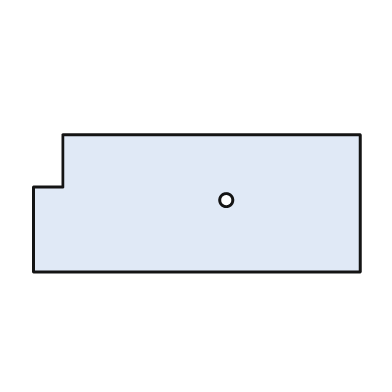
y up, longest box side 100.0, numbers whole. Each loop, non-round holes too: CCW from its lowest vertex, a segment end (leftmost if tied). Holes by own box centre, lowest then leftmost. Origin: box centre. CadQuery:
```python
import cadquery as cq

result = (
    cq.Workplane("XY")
    .moveTo(-50.0, -21.0)
    .lineTo(50.0, -21.0)
    .lineTo(50.0, 21.0)
    .lineTo(-41.0, 21.0)
    .lineTo(-41.0, 5.0)
    .lineTo(-50.0, 5.0)
    .close()
    .moveTo(9.0, 1.0)
    .circle(2.0)
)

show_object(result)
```